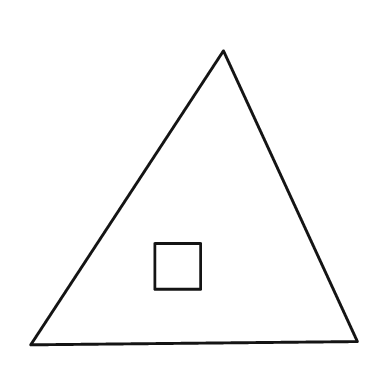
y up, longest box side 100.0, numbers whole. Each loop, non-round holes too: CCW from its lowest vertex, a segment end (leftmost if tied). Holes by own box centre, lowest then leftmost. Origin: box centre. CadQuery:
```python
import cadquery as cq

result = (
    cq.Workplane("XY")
    .moveTo(-50.0, -45.0)
    .lineTo(50.0, -44.0)
    .lineTo(9.0, 45.0)
    .close()
    .moveTo(-12.0, -28.0)
    .lineTo(2.0, -28.0)
    .lineTo(2.0, -14.0)
    .lineTo(-12.0, -14.0)
    .close()
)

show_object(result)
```